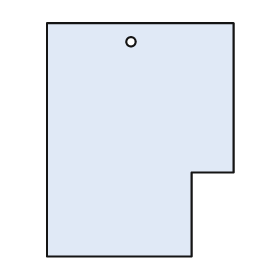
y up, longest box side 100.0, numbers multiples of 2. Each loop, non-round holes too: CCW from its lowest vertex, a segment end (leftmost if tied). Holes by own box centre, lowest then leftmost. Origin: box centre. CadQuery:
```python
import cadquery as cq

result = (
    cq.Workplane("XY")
    .moveTo(-40.0, -50.0)
    .lineTo(22.0, -50.0)
    .lineTo(22.0, -14.0)
    .lineTo(40.0, -14.0)
    .lineTo(40.0, 50.0)
    .lineTo(-40.0, 50.0)
    .close()
    .moveTo(-4.0, 42.0)
    .circle(2.0)
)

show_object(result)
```